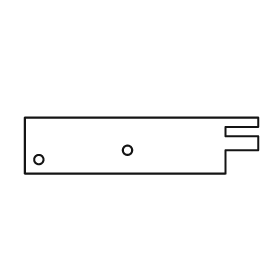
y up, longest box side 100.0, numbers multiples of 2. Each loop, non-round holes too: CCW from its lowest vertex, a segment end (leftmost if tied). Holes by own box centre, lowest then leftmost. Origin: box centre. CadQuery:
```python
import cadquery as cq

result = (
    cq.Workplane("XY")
    .moveTo(-50.0, -12.0)
    .lineTo(36.0, -12.0)
    .lineTo(36.0, -2.0)
    .lineTo(50.0, -2.0)
    .lineTo(50.0, 4.0)
    .lineTo(36.0, 4.0)
    .lineTo(36.0, 8.0)
    .lineTo(50.0, 8.0)
    .lineTo(50.0, 12.0)
    .lineTo(-50.0, 12.0)
    .close()
    .moveTo(-44.0, -6.0)
    .circle(2.0)
    .moveTo(-6.0, -2.0)
    .circle(2.0)
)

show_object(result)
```